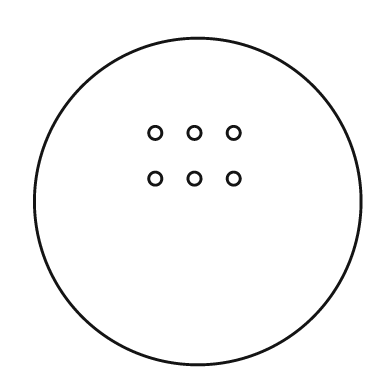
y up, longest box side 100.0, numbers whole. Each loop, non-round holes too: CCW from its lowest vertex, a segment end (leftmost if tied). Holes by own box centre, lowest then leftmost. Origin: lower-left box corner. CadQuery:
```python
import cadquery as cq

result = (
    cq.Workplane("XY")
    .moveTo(50.0, 50.0)
    .circle(50.0)
    .moveTo(37.0, 57.0)
    .circle(2.0)
    .moveTo(49.0, 57.0)
    .circle(2.0)
    .moveTo(61.0, 57.0)
    .circle(2.0)
    .moveTo(37.0, 71.0)
    .circle(2.0)
    .moveTo(49.0, 71.0)
    .circle(2.0)
    .moveTo(61.0, 71.0)
    .circle(2.0)
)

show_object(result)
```